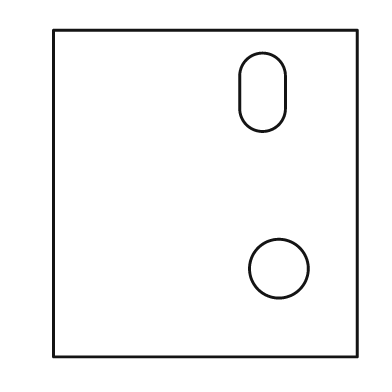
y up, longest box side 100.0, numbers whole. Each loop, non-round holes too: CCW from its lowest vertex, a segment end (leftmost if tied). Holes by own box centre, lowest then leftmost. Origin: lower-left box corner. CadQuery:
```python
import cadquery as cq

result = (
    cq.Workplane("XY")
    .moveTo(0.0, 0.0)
    .lineTo(93.0, 0.0)
    .lineTo(93.0, 100.0)
    .lineTo(0.0, 100.0)
    .close()
    .moveTo(69.0, 27.0)
    .circle(9.0)
    .moveTo(57.0, 76.0)
    .threePointArc((64.0, 69.0), (71.0, 76.0))
    .lineTo(71.0, 86.0)
    .threePointArc((64.0, 93.0), (57.0, 86.0))
    .close()
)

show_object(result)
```